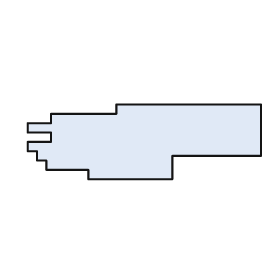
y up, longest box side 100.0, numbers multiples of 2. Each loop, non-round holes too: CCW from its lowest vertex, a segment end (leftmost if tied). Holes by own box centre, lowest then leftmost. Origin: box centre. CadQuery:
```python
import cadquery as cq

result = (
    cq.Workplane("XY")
    .moveTo(-24.0, -16.0)
    .lineTo(12.0, -16.0)
    .lineTo(12.0, -6.0)
    .lineTo(50.0, -6.0)
    .lineTo(50.0, 16.0)
    .lineTo(-12.0, 16.0)
    .lineTo(-12.0, 12.0)
    .lineTo(-40.0, 12.0)
    .lineTo(-40.0, 8.0)
    .lineTo(-50.0, 8.0)
    .lineTo(-50.0, 4.0)
    .lineTo(-40.0, 4.0)
    .lineTo(-40.0, 0.0)
    .lineTo(-50.0, 0.0)
    .lineTo(-50.0, -4.0)
    .lineTo(-46.0, -4.0)
    .lineTo(-46.0, -8.0)
    .lineTo(-42.0, -8.0)
    .lineTo(-42.0, -12.0)
    .lineTo(-24.0, -12.0)
    .close()
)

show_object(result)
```